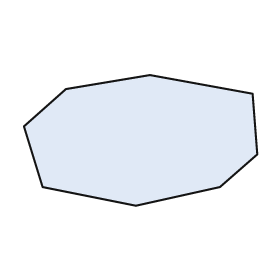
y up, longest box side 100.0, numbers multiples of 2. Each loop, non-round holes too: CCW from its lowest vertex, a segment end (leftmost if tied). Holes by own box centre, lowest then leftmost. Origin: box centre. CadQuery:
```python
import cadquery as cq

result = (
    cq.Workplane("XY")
    .moveTo(-2.0, -28.0)
    .lineTo(34.0, -20.0)
    .lineTo(50.0, -6.0)
    .lineTo(48.0, 20.0)
    .lineTo(4.0, 28.0)
    .lineTo(-32.0, 22.0)
    .lineTo(-50.0, 6.0)
    .lineTo(-42.0, -20.0)
    .close()
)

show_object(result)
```